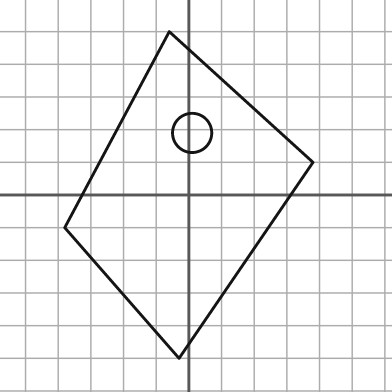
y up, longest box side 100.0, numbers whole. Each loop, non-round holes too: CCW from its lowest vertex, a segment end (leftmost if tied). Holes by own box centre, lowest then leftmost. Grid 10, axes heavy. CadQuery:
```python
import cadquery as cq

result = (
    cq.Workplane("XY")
    .moveTo(-3.0, -50.0)
    .lineTo(38.0, 10.0)
    .lineTo(-6.0, 50.0)
    .lineTo(-38.0, -10.0)
    .close()
    .moveTo(1.0, 19.0)
    .circle(6.0)
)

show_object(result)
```